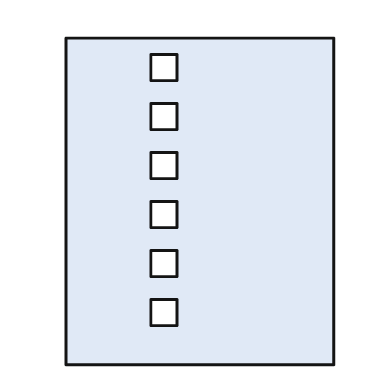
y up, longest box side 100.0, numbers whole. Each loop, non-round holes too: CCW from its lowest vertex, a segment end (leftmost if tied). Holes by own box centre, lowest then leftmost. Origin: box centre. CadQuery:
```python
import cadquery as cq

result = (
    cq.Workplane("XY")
    .moveTo(-41.0, -50.0)
    .lineTo(41.0, -50.0)
    .lineTo(41.0, 50.0)
    .lineTo(-41.0, 50.0)
    .close()
    .moveTo(-15.0, -38.0)
    .lineTo(-7.0, -38.0)
    .lineTo(-7.0, -30.0)
    .lineTo(-15.0, -30.0)
    .close()
    .moveTo(-15.0, -23.0)
    .lineTo(-7.0, -23.0)
    .lineTo(-7.0, -15.0)
    .lineTo(-15.0, -15.0)
    .close()
    .moveTo(-15.0, -8.0)
    .lineTo(-7.0, -8.0)
    .lineTo(-7.0, 0.0)
    .lineTo(-15.0, 0.0)
    .close()
    .moveTo(-15.0, 7.0)
    .lineTo(-7.0, 7.0)
    .lineTo(-7.0, 15.0)
    .lineTo(-15.0, 15.0)
    .close()
    .moveTo(-15.0, 22.0)
    .lineTo(-7.0, 22.0)
    .lineTo(-7.0, 30.0)
    .lineTo(-15.0, 30.0)
    .close()
    .moveTo(-15.0, 37.0)
    .lineTo(-7.0, 37.0)
    .lineTo(-7.0, 45.0)
    .lineTo(-15.0, 45.0)
    .close()
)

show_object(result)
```